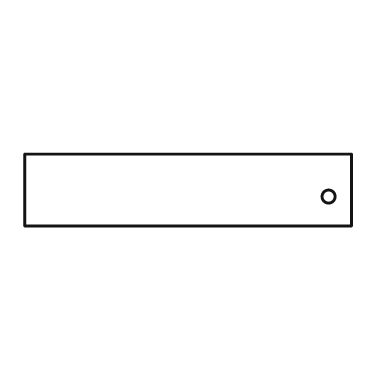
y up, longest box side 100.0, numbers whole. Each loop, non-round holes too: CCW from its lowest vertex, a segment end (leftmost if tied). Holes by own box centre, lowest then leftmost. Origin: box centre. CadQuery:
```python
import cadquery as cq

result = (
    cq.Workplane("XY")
    .moveTo(-50.0, -11.0)
    .lineTo(50.0, -11.0)
    .lineTo(50.0, 11.0)
    .lineTo(-50.0, 11.0)
    .close()
    .moveTo(43.0, -2.0)
    .circle(2.0)
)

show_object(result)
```